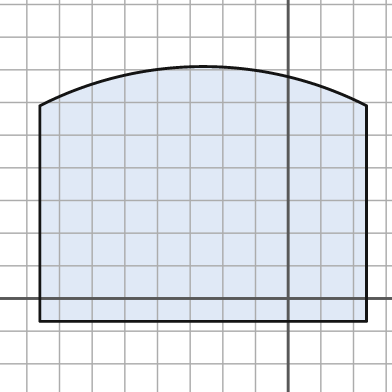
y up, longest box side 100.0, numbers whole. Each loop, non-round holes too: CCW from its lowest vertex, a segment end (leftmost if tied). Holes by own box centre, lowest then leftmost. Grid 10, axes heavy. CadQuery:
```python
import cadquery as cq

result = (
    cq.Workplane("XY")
    .moveTo(-76.0, -7.0)
    .lineTo(24.0, -7.0)
    .lineTo(24.0, 59.0)
    .threePointArc((-26.0, 71.0), (-76.0, 59.0))
    .close()
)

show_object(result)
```